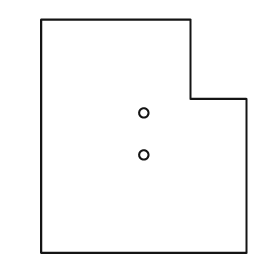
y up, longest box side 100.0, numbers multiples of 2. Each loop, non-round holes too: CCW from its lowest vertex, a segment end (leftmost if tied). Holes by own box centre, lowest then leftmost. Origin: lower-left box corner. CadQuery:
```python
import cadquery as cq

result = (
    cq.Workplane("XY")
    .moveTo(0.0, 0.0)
    .lineTo(88.0, 0.0)
    .lineTo(88.0, 66.0)
    .lineTo(64.0, 66.0)
    .lineTo(64.0, 100.0)
    .lineTo(0.0, 100.0)
    .close()
    .moveTo(44.0, 42.0)
    .circle(2.0)
    .moveTo(44.0, 60.0)
    .circle(2.0)
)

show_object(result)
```